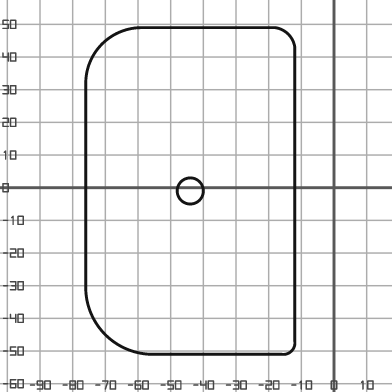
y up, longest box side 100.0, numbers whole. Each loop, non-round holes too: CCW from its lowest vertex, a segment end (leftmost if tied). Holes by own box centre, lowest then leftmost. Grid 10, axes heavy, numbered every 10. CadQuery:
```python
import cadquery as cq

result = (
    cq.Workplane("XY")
    .moveTo(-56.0, -51.0)
    .lineTo(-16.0, -51.0)
    .threePointArc((-13.0, -50.0), (-12.0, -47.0))
    .lineTo(-12.0, 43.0)
    .threePointArc((-14.0, 47.0), (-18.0, 49.0))
    .lineTo(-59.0, 49.0)
    .threePointArc((-71.0, 44.0), (-76.0, 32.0))
    .lineTo(-76.0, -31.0)
    .threePointArc((-70.0, -45.0), (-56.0, -51.0))
    .close()
    .moveTo(-44.0, -1.0)
    .circle(4.0)
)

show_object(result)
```